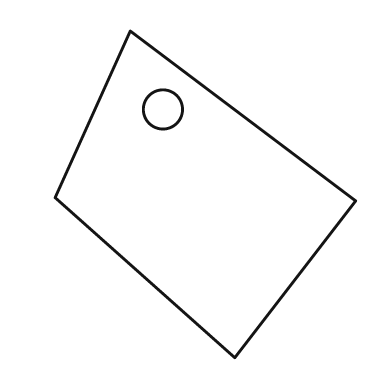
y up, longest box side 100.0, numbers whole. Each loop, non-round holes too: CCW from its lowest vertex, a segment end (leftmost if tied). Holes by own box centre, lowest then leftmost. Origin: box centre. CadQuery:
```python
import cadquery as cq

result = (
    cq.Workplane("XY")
    .moveTo(9.0, -50.0)
    .lineTo(46.0, -2.0)
    .lineTo(-23.0, 50.0)
    .lineTo(-46.0, -1.0)
    .close()
    .moveTo(-13.0, 26.0)
    .circle(6.0)
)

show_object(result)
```